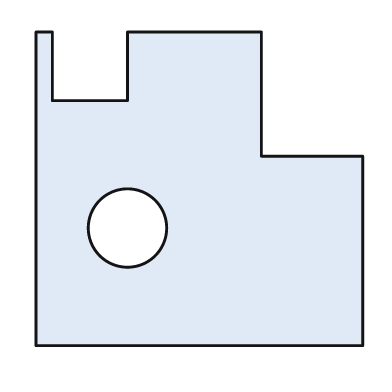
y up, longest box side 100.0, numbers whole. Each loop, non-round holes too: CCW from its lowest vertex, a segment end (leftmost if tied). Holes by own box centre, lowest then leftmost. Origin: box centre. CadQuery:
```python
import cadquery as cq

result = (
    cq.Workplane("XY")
    .moveTo(-50.0, -48.0)
    .lineTo(50.0, -48.0)
    .lineTo(50.0, 10.0)
    .lineTo(19.0, 10.0)
    .lineTo(19.0, 48.0)
    .lineTo(-22.0, 48.0)
    .lineTo(-22.0, 27.0)
    .lineTo(-45.0, 27.0)
    .lineTo(-45.0, 48.0)
    .lineTo(-50.0, 48.0)
    .close()
    .moveTo(-22.0, -12.0)
    .circle(12.0)
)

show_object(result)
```